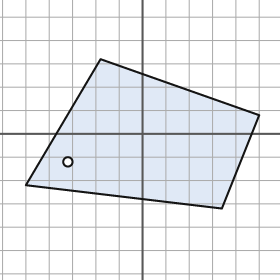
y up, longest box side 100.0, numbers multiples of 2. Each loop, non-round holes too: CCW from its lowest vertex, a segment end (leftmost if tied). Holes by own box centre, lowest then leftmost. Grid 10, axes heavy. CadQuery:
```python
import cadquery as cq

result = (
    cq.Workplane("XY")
    .moveTo(34.0, -32.0)
    .lineTo(50.0, 8.0)
    .lineTo(-18.0, 32.0)
    .lineTo(-50.0, -22.0)
    .close()
    .moveTo(-32.0, -12.0)
    .circle(2.0)
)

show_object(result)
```